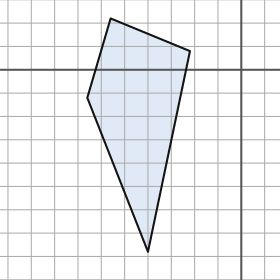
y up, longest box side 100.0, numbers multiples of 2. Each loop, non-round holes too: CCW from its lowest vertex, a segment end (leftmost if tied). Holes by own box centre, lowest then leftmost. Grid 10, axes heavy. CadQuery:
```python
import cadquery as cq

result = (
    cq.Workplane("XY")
    .moveTo(-40.0, -78.0)
    .lineTo(-22.0, 8.0)
    .lineTo(-56.0, 22.0)
    .lineTo(-66.0, -12.0)
    .close()
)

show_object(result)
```